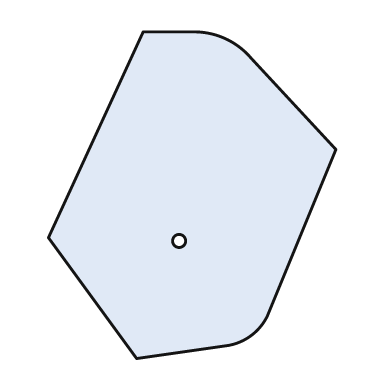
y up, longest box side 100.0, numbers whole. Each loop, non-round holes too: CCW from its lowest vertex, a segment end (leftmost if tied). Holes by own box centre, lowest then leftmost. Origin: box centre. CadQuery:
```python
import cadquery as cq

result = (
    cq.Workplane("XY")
    .moveTo(-17.0, -50.0)
    .lineTo(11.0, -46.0)
    .threePointArc((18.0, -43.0), (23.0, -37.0))
    .lineTo(44.0, 14.0)
    .lineTo(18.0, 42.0)
    .threePointArc((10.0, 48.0), (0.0, 50.0))
    .lineTo(-15.0, 50.0)
    .lineTo(-44.0, -13.0)
    .close()
    .moveTo(-4.0, -14.0)
    .circle(2.0)
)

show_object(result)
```